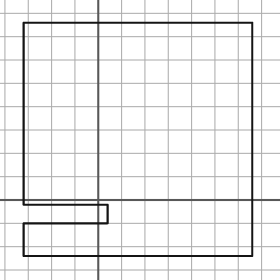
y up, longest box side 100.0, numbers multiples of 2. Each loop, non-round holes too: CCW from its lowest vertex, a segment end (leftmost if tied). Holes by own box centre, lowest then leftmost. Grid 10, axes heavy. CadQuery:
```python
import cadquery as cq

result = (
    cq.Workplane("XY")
    .moveTo(-32.0, -24.0)
    .lineTo(66.0, -24.0)
    .lineTo(66.0, 76.0)
    .lineTo(-32.0, 76.0)
    .lineTo(-32.0, -2.0)
    .lineTo(4.0, -2.0)
    .lineTo(4.0, -10.0)
    .lineTo(-32.0, -10.0)
    .close()
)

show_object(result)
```